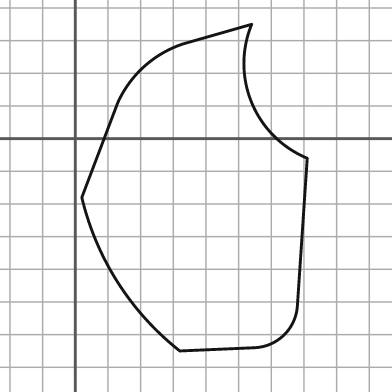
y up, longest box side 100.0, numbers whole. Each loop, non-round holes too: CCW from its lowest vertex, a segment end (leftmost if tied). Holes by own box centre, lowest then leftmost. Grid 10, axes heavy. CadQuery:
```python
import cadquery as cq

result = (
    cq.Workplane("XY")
    .moveTo(32.0, -65.0)
    .lineTo(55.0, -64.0)
    .threePointArc((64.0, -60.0), (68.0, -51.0))
    .lineTo(71.0, -6.0)
    .threePointArc((54.0, 11.0), (54.0, 35.0))
    .lineTo(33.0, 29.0)
    .threePointArc((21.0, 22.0), (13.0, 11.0))
    .lineTo(2.0, -18.0)
    .threePointArc((13.0, -44.0), (32.0, -65.0))
    .close()
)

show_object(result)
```